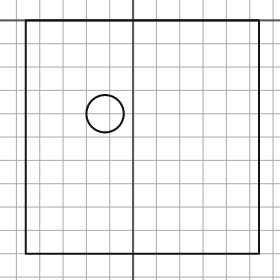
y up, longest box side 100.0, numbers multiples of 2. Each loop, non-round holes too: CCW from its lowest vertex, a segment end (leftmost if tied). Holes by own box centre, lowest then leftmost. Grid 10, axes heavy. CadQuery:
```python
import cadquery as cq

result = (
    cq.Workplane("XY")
    .moveTo(-46.0, -100.0)
    .lineTo(54.0, -100.0)
    .lineTo(54.0, 0.0)
    .lineTo(-46.0, 0.0)
    .close()
    .moveTo(-12.0, -40.0)
    .circle(8.0)
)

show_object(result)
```